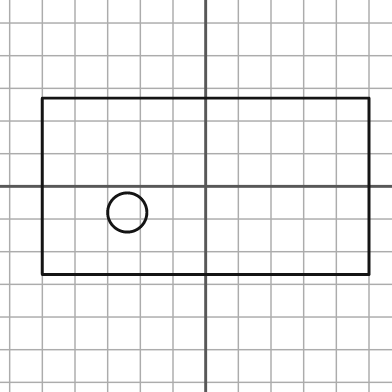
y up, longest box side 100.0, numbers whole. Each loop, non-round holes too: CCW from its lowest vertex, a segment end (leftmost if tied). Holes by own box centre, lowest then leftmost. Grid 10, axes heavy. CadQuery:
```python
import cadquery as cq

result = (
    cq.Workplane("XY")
    .moveTo(-50.0, -27.0)
    .lineTo(50.0, -27.0)
    .lineTo(50.0, 27.0)
    .lineTo(-50.0, 27.0)
    .close()
    .moveTo(-24.0, -8.0)
    .circle(6.0)
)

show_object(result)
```